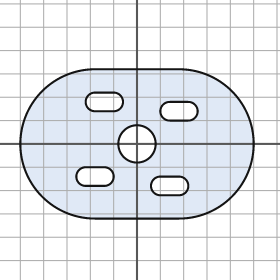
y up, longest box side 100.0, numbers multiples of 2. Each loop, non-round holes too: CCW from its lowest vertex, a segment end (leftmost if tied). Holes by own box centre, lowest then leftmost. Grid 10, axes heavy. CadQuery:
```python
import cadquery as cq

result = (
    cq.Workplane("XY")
    .moveTo(-18.0, -32.0)
    .lineTo(18.0, -32.0)
    .threePointArc((50.0, 0.0), (18.0, 32.0))
    .lineTo(-18.0, 32.0)
    .threePointArc((-50.0, 0.0), (-18.0, -32.0))
    .close()
    .moveTo(10.0, -22.0)
    .lineTo(18.0, -22.0)
    .threePointArc((22.0, -18.0), (18.0, -14.0))
    .lineTo(10.0, -14.0)
    .threePointArc((6.0, -18.0), (10.0, -22.0))
    .close()
    .moveTo(-22.0, -18.0)
    .lineTo(-14.0, -18.0)
    .threePointArc((-10.0, -14.0), (-14.0, -10.0))
    .lineTo(-22.0, -10.0)
    .threePointArc((-26.0, -14.0), (-22.0, -18.0))
    .close()
    .moveTo(0.0, 0.0)
    .circle(8.0)
    .moveTo(14.0, 10.0)
    .lineTo(22.0, 10.0)
    .threePointArc((26.0, 14.0), (22.0, 18.0))
    .lineTo(14.0, 18.0)
    .threePointArc((10.0, 14.0), (14.0, 10.0))
    .close()
    .moveTo(-18.0, 14.0)
    .lineTo(-10.0, 14.0)
    .threePointArc((-6.0, 18.0), (-10.0, 22.0))
    .lineTo(-18.0, 22.0)
    .threePointArc((-22.0, 18.0), (-18.0, 14.0))
    .close()
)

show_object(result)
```